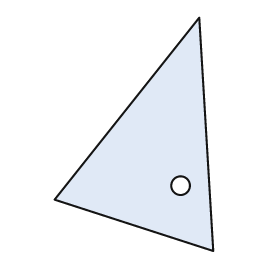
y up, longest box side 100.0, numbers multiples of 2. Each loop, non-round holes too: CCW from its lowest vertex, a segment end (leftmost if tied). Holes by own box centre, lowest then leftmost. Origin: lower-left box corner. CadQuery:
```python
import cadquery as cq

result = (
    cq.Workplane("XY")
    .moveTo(68.0, 0.0)
    .lineTo(62.0, 100.0)
    .lineTo(0.0, 22.0)
    .close()
    .moveTo(54.0, 28.0)
    .circle(4.0)
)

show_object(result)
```